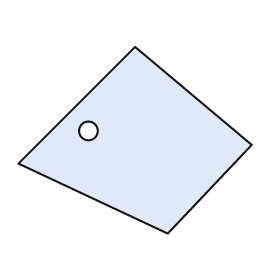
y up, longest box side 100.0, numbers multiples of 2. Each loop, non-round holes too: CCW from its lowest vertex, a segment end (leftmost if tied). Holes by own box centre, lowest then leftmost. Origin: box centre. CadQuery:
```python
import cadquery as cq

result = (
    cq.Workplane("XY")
    .moveTo(14.0, -40.0)
    .lineTo(50.0, -2.0)
    .lineTo(0.0, 40.0)
    .lineTo(-50.0, -10.0)
    .close()
    .moveTo(-20.0, 4.0)
    .circle(4.0)
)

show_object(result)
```